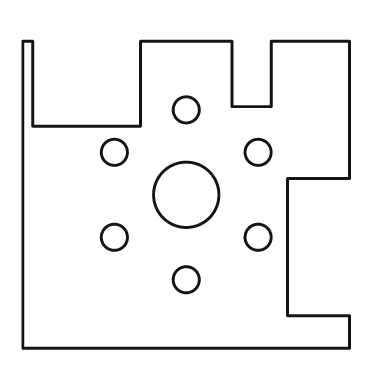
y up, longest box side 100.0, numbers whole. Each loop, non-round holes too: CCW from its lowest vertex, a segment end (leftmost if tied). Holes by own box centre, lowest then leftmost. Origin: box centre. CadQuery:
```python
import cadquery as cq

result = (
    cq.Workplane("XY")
    .moveTo(-50.0, -47.0)
    .lineTo(50.0, -47.0)
    .lineTo(50.0, -37.0)
    .lineTo(31.0, -37.0)
    .lineTo(31.0, 5.0)
    .lineTo(50.0, 5.0)
    .lineTo(50.0, 47.0)
    .lineTo(26.0, 47.0)
    .lineTo(26.0, 27.0)
    .lineTo(14.0, 27.0)
    .lineTo(14.0, 47.0)
    .lineTo(-14.0, 47.0)
    .lineTo(-14.0, 21.0)
    .lineTo(-47.0, 21.0)
    .lineTo(-47.0, 47.0)
    .lineTo(-50.0, 47.0)
    .close()
    .moveTo(0.0, -26.0)
    .circle(4.0)
    .moveTo(-22.0, -13.0)
    .circle(4.0)
    .moveTo(22.0, -13.0)
    .circle(4.0)
    .moveTo(0.0, 0.0)
    .circle(10.0)
    .moveTo(-22.0, 13.0)
    .circle(4.0)
    .moveTo(22.0, 13.0)
    .circle(4.0)
    .moveTo(0.0, 26.0)
    .circle(4.0)
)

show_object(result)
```